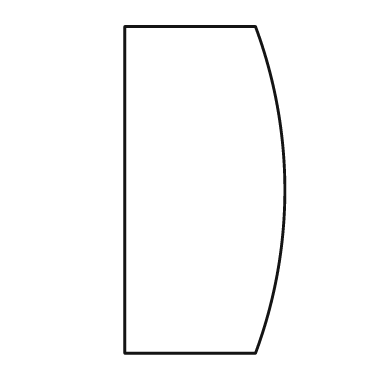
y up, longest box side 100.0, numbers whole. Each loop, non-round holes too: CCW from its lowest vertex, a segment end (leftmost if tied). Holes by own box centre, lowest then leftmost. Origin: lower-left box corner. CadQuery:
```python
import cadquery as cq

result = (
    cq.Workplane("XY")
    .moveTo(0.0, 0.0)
    .lineTo(40.0, 0.0)
    .threePointArc((49.0, 50.0), (40.0, 100.0))
    .lineTo(0.0, 100.0)
    .close()
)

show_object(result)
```